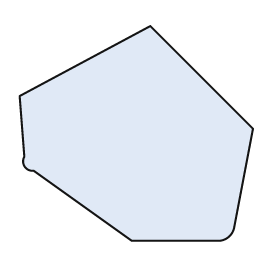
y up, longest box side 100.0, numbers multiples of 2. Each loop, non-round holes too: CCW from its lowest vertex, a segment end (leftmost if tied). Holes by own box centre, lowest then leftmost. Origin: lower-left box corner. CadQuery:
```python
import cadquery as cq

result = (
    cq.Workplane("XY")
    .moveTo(48.0, 0.0)
    .lineTo(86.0, 0.0)
    .threePointArc((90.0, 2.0), (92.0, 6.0))
    .lineTo(100.0, 48.0)
    .lineTo(56.0, 92.0)
    .lineTo(0.0, 62.0)
    .lineTo(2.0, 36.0)
    .threePointArc((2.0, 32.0), (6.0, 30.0))
    .close()
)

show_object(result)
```